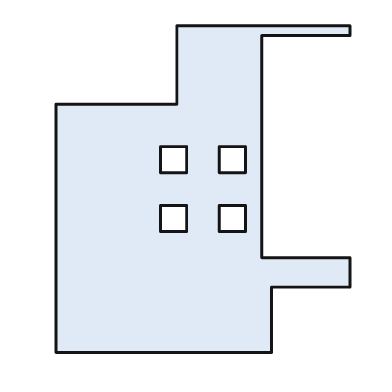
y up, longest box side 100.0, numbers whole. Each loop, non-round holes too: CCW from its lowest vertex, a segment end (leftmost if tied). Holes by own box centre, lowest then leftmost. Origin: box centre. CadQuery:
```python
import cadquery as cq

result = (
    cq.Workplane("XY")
    .moveTo(-45.0, -50.0)
    .lineTo(21.0, -50.0)
    .lineTo(21.0, -30.0)
    .lineTo(45.0, -30.0)
    .lineTo(45.0, -21.0)
    .lineTo(18.0, -21.0)
    .lineTo(18.0, 47.0)
    .lineTo(45.0, 47.0)
    .lineTo(45.0, 50.0)
    .lineTo(-8.0, 50.0)
    .lineTo(-8.0, 26.0)
    .lineTo(-45.0, 26.0)
    .close()
    .moveTo(-13.0, -13.0)
    .lineTo(-5.0, -13.0)
    .lineTo(-5.0, -5.0)
    .lineTo(-13.0, -5.0)
    .close()
    .moveTo(5.0, -13.0)
    .lineTo(13.0, -13.0)
    .lineTo(13.0, -5.0)
    .lineTo(5.0, -5.0)
    .close()
    .moveTo(-13.0, 5.0)
    .lineTo(-5.0, 5.0)
    .lineTo(-5.0, 13.0)
    .lineTo(-13.0, 13.0)
    .close()
    .moveTo(5.0, 5.0)
    .lineTo(13.0, 5.0)
    .lineTo(13.0, 13.0)
    .lineTo(5.0, 13.0)
    .close()
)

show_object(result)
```